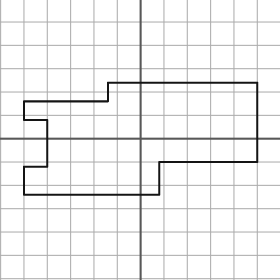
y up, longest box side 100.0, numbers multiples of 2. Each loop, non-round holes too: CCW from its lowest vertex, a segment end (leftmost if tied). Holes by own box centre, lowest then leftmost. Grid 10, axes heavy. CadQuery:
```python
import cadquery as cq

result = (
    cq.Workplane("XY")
    .moveTo(-50.0, -24.0)
    .lineTo(8.0, -24.0)
    .lineTo(8.0, -10.0)
    .lineTo(50.0, -10.0)
    .lineTo(50.0, 24.0)
    .lineTo(-14.0, 24.0)
    .lineTo(-14.0, 16.0)
    .lineTo(-50.0, 16.0)
    .lineTo(-50.0, 8.0)
    .lineTo(-40.0, 8.0)
    .lineTo(-40.0, -12.0)
    .lineTo(-50.0, -12.0)
    .close()
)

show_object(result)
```